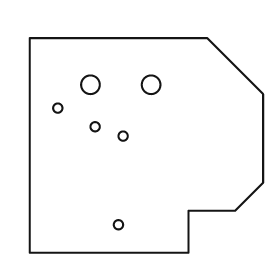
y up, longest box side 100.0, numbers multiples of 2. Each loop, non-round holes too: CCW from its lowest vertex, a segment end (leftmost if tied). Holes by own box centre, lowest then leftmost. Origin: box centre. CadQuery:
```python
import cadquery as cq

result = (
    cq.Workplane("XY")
    .moveTo(-50.0, -46.0)
    .lineTo(18.0, -46.0)
    .lineTo(18.0, -28.0)
    .lineTo(38.0, -28.0)
    .lineTo(50.0, -16.0)
    .lineTo(50.0, 22.0)
    .lineTo(26.0, 46.0)
    .lineTo(-50.0, 46.0)
    .close()
    .moveTo(-12.0, -34.0)
    .circle(2.0)
    .moveTo(-10.0, 4.0)
    .circle(2.0)
    .moveTo(-22.0, 8.0)
    .circle(2.0)
    .moveTo(-38.0, 16.0)
    .circle(2.0)
    .moveTo(-24.0, 26.0)
    .circle(4.0)
    .moveTo(2.0, 26.0)
    .circle(4.0)
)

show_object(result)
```